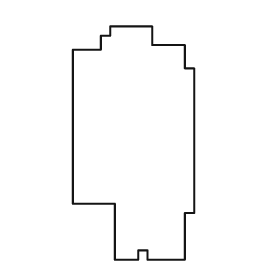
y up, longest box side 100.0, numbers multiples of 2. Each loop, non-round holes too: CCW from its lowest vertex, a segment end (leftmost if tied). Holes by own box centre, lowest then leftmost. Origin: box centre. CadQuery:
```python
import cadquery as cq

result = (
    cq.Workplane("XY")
    .moveTo(-8.0, -50.0)
    .lineTo(2.0, -50.0)
    .lineTo(2.0, -46.0)
    .lineTo(6.0, -46.0)
    .lineTo(6.0, -50.0)
    .lineTo(22.0, -50.0)
    .lineTo(22.0, -30.0)
    .lineTo(26.0, -30.0)
    .lineTo(26.0, 32.0)
    .lineTo(22.0, 32.0)
    .lineTo(22.0, 42.0)
    .lineTo(8.0, 42.0)
    .lineTo(8.0, 50.0)
    .lineTo(-10.0, 50.0)
    .lineTo(-10.0, 46.0)
    .lineTo(-14.0, 46.0)
    .lineTo(-14.0, 40.0)
    .lineTo(-26.0, 40.0)
    .lineTo(-26.0, -26.0)
    .lineTo(-8.0, -26.0)
    .close()
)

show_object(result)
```